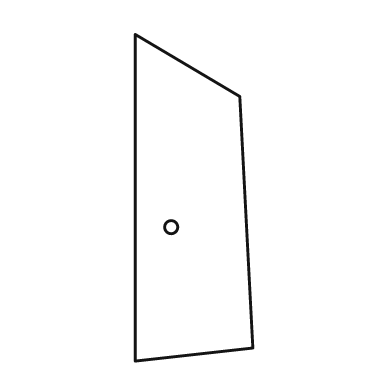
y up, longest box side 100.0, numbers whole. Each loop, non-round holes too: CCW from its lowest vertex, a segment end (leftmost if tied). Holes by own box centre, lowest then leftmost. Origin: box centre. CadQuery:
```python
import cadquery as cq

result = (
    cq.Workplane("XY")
    .moveTo(-18.0, -50.0)
    .lineTo(18.0, -46.0)
    .lineTo(14.0, 31.0)
    .lineTo(-18.0, 50.0)
    .close()
    .moveTo(-7.0, -9.0)
    .circle(2.0)
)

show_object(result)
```